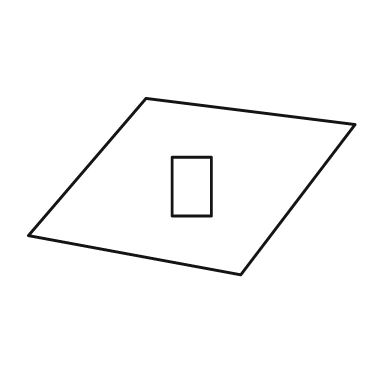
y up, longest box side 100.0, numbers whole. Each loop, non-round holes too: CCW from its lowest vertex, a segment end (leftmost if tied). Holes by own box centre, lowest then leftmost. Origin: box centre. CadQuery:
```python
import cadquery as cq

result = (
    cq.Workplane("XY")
    .moveTo(15.0, -27.0)
    .lineTo(50.0, 19.0)
    .lineTo(-14.0, 27.0)
    .lineTo(-50.0, -15.0)
    .close()
    .moveTo(-6.0, -9.0)
    .lineTo(6.0, -9.0)
    .lineTo(6.0, 9.0)
    .lineTo(-6.0, 9.0)
    .close()
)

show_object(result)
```